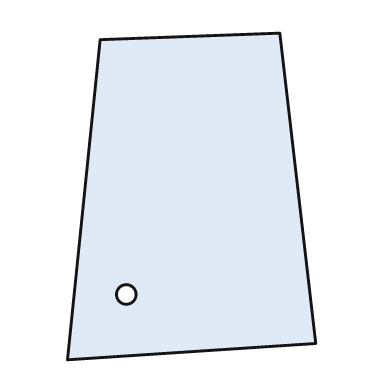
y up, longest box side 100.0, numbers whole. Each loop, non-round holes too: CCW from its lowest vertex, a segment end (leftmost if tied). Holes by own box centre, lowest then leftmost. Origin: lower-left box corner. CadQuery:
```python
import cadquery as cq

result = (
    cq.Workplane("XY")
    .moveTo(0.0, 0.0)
    .lineTo(76.0, 5.0)
    .lineTo(65.0, 100.0)
    .lineTo(10.0, 98.0)
    .close()
    .moveTo(18.0, 20.0)
    .circle(3.0)
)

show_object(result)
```